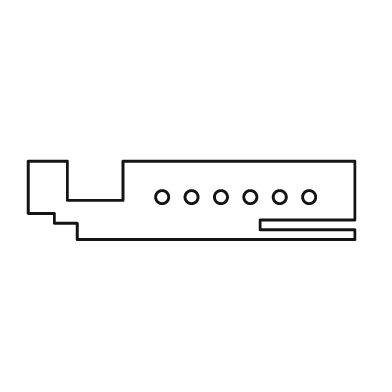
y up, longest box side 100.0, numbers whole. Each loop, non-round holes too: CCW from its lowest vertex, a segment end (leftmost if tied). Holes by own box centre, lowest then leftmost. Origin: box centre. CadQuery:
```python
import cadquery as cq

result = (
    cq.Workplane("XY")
    .moveTo(-35.0, -12.0)
    .lineTo(50.0, -12.0)
    .lineTo(50.0, -9.0)
    .lineTo(21.0, -9.0)
    .lineTo(21.0, -6.0)
    .lineTo(50.0, -6.0)
    .lineTo(50.0, 12.0)
    .lineTo(-21.0, 12.0)
    .lineTo(-21.0, 0.0)
    .lineTo(-38.0, 0.0)
    .lineTo(-38.0, 12.0)
    .lineTo(-50.0, 12.0)
    .lineTo(-50.0, -4.0)
    .lineTo(-42.0, -4.0)
    .lineTo(-42.0, -7.0)
    .lineTo(-35.0, -7.0)
    .close()
    .moveTo(-9.0, 1.0)
    .circle(2.0)
    .moveTo(0.0, 1.0)
    .circle(2.0)
    .moveTo(9.0, 1.0)
    .circle(2.0)
    .moveTo(18.0, 1.0)
    .circle(2.0)
    .moveTo(27.0, 1.0)
    .circle(2.0)
    .moveTo(36.0, 1.0)
    .circle(2.0)
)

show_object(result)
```